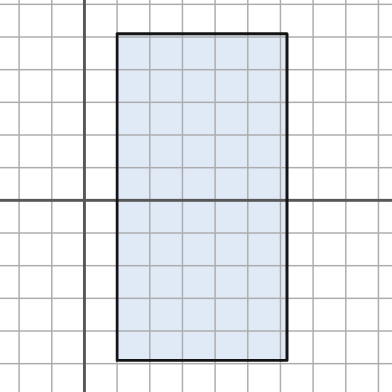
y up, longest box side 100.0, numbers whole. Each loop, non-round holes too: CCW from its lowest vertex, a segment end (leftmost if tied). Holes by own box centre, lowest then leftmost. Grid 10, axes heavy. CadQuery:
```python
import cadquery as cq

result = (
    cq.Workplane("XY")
    .moveTo(10.0, -49.0)
    .lineTo(62.0, -49.0)
    .lineTo(62.0, 51.0)
    .lineTo(10.0, 51.0)
    .close()
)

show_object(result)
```